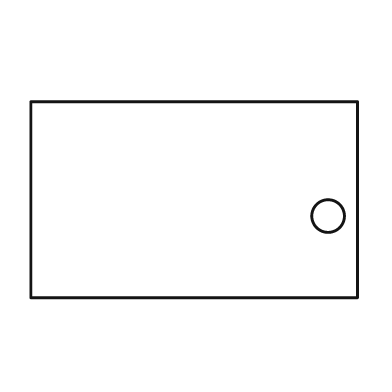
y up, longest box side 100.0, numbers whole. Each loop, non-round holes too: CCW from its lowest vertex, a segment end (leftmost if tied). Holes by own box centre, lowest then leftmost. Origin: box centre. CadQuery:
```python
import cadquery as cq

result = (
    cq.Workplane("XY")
    .moveTo(-50.0, -30.0)
    .lineTo(50.0, -30.0)
    .lineTo(50.0, 30.0)
    .lineTo(-50.0, 30.0)
    .close()
    .moveTo(41.0, -5.0)
    .circle(5.0)
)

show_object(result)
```